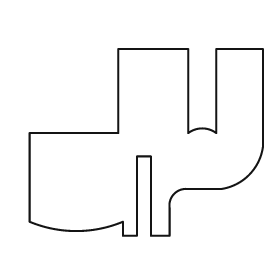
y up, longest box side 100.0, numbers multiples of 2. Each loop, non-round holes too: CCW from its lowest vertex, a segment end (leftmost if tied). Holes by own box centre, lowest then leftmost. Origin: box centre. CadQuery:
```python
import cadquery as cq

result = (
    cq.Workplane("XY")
    .moveTo(-10.0, -40.0)
    .lineTo(-4.0, -40.0)
    .lineTo(-4.0, -6.0)
    .lineTo(2.0, -6.0)
    .lineTo(2.0, -40.0)
    .lineTo(10.0, -40.0)
    .lineTo(10.0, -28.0)
    .threePointArc((12.0, -22.0), (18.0, -20.0))
    .lineTo(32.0, -20.0)
    .threePointArc((44.0, -14.0), (50.0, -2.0))
    .lineTo(50.0, 40.0)
    .lineTo(30.0, 40.0)
    .lineTo(30.0, 4.0)
    .threePointArc((24.0, 6.0), (18.0, 4.0))
    .lineTo(18.0, 40.0)
    .lineTo(-12.0, 40.0)
    .lineTo(-12.0, 4.0)
    .lineTo(-50.0, 4.0)
    .lineTo(-50.0, -34.0)
    .threePointArc((-30.0, -38.0), (-10.0, -34.0))
    .close()
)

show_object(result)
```